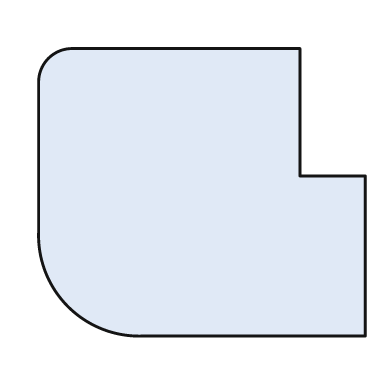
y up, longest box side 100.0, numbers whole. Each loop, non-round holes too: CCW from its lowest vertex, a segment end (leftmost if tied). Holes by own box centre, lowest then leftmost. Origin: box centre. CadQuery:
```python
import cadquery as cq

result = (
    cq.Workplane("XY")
    .moveTo(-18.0, -44.0)
    .lineTo(50.0, -44.0)
    .lineTo(50.0, 5.0)
    .lineTo(30.0, 5.0)
    .lineTo(30.0, 44.0)
    .lineTo(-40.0, 44.0)
    .threePointArc((-47.0, 41.0), (-50.0, 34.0))
    .lineTo(-50.0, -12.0)
    .threePointArc((-41.0, -35.0), (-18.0, -44.0))
    .close()
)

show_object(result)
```